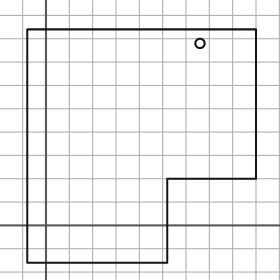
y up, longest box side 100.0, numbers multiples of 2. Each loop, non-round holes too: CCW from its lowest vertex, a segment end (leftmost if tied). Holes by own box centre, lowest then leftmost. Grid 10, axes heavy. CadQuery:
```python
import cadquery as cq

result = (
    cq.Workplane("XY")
    .moveTo(-8.0, -16.0)
    .lineTo(52.0, -16.0)
    .lineTo(52.0, 20.0)
    .lineTo(90.0, 20.0)
    .lineTo(90.0, 84.0)
    .lineTo(-8.0, 84.0)
    .close()
    .moveTo(66.0, 78.0)
    .circle(2.0)
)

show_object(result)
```